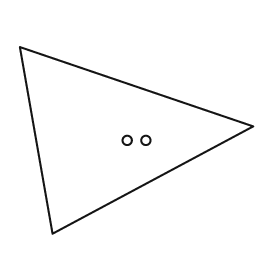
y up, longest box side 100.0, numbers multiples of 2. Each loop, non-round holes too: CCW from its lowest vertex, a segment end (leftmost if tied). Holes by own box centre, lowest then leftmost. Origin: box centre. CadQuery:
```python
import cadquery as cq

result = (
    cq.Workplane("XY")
    .moveTo(-36.0, -40.0)
    .lineTo(50.0, 6.0)
    .lineTo(-50.0, 40.0)
    .close()
    .moveTo(-4.0, 0.0)
    .circle(2.0)
    .moveTo(4.0, 0.0)
    .circle(2.0)
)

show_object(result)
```